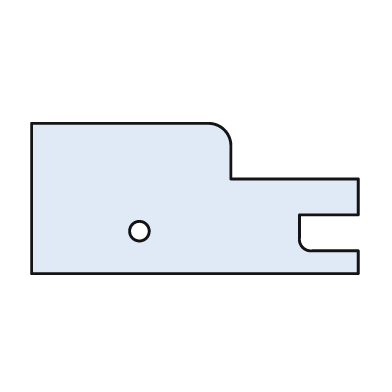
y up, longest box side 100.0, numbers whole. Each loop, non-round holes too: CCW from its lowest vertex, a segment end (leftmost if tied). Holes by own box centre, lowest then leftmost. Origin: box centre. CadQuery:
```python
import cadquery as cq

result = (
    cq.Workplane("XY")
    .moveTo(-50.0, -23.0)
    .lineTo(50.0, -23.0)
    .lineTo(50.0, -16.0)
    .lineTo(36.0, -16.0)
    .threePointArc((33.0, -15.0), (32.0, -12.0))
    .lineTo(32.0, -5.0)
    .lineTo(50.0, -5.0)
    .lineTo(50.0, 6.0)
    .lineTo(11.0, 6.0)
    .lineTo(11.0, 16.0)
    .threePointArc((9.0, 21.0), (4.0, 23.0))
    .lineTo(-50.0, 23.0)
    .close()
    .moveTo(-17.0, -10.0)
    .circle(3.0)
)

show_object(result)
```